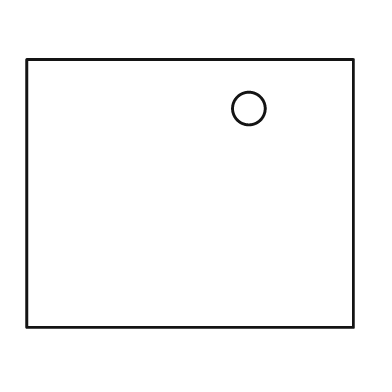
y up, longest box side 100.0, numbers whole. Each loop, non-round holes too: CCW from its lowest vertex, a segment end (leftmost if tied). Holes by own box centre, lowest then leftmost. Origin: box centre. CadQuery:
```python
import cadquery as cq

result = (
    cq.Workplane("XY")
    .moveTo(-50.0, -41.0)
    .lineTo(50.0, -41.0)
    .lineTo(50.0, 41.0)
    .lineTo(-50.0, 41.0)
    .close()
    .moveTo(18.0, 26.0)
    .circle(5.0)
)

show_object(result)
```